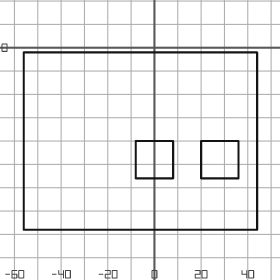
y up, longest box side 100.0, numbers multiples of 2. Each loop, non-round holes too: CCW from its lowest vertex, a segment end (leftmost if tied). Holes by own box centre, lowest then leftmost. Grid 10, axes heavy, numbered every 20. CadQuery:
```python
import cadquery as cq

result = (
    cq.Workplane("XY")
    .moveTo(-56.0, -78.0)
    .lineTo(44.0, -78.0)
    .lineTo(44.0, -2.0)
    .lineTo(-56.0, -2.0)
    .close()
    .moveTo(-8.0, -56.0)
    .lineTo(8.0, -56.0)
    .lineTo(8.0, -40.0)
    .lineTo(-8.0, -40.0)
    .close()
    .moveTo(20.0, -56.0)
    .lineTo(36.0, -56.0)
    .lineTo(36.0, -40.0)
    .lineTo(20.0, -40.0)
    .close()
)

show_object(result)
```